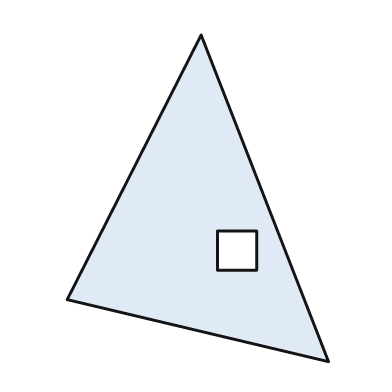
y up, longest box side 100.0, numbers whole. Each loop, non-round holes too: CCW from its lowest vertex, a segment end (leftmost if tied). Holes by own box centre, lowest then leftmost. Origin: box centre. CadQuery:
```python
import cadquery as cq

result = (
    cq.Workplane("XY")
    .moveTo(40.0, -50.0)
    .lineTo(1.0, 50.0)
    .lineTo(-40.0, -31.0)
    .close()
    .moveTo(6.0, -22.0)
    .lineTo(18.0, -22.0)
    .lineTo(18.0, -10.0)
    .lineTo(6.0, -10.0)
    .close()
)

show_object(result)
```